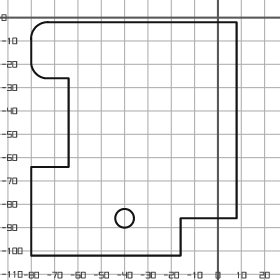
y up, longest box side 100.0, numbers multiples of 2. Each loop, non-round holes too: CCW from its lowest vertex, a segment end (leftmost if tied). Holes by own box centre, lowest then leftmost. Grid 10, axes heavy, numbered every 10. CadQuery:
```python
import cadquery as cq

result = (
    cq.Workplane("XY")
    .moveTo(-80.0, -102.0)
    .lineTo(-16.0, -102.0)
    .lineTo(-16.0, -86.0)
    .lineTo(8.0, -86.0)
    .lineTo(8.0, -2.0)
    .lineTo(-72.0, -2.0)
    .threePointArc((-78.0, -4.0), (-80.0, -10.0))
    .lineTo(-80.0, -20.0)
    .threePointArc((-78.0, -24.0), (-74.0, -26.0))
    .lineTo(-64.0, -26.0)
    .lineTo(-64.0, -64.0)
    .lineTo(-80.0, -64.0)
    .close()
    .moveTo(-40.0, -86.0)
    .circle(4.0)
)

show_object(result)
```